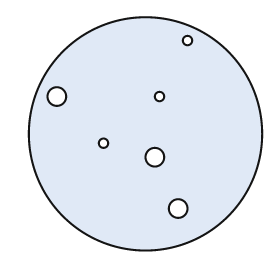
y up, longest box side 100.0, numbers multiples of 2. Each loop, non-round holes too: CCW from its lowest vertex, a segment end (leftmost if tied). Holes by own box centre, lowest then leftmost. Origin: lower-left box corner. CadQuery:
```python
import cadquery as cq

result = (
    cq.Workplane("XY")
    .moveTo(50.0, 50.0)
    .circle(50.0)
    .moveTo(64.0, 18.0)
    .circle(4.0)
    .moveTo(54.0, 40.0)
    .circle(4.0)
    .moveTo(32.0, 46.0)
    .circle(2.0)
    .moveTo(12.0, 66.0)
    .circle(4.0)
    .moveTo(56.0, 66.0)
    .circle(2.0)
    .moveTo(68.0, 90.0)
    .circle(2.0)
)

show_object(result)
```